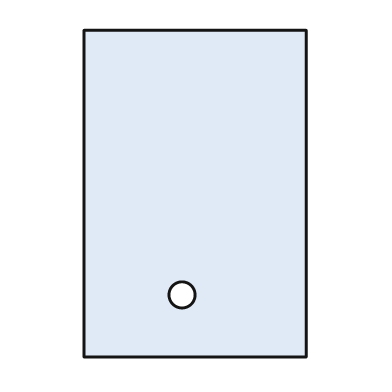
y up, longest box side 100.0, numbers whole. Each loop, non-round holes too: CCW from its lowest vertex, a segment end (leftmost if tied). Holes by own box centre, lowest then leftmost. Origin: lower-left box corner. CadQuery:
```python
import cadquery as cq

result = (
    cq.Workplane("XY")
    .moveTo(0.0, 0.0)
    .lineTo(68.0, 0.0)
    .lineTo(68.0, 100.0)
    .lineTo(0.0, 100.0)
    .close()
    .moveTo(30.0, 19.0)
    .circle(4.0)
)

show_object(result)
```